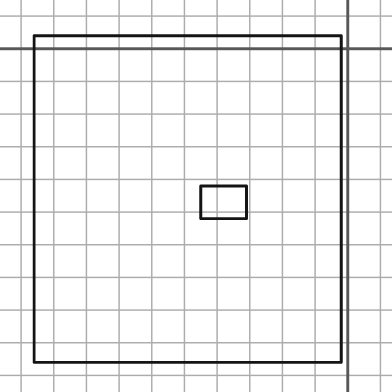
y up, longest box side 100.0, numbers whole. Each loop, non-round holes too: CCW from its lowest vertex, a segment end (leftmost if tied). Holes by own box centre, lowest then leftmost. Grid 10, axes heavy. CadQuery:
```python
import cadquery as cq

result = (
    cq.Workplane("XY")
    .moveTo(-96.0, -96.0)
    .lineTo(-2.0, -96.0)
    .lineTo(-2.0, 4.0)
    .lineTo(-96.0, 4.0)
    .close()
    .moveTo(-45.0, -52.0)
    .lineTo(-31.0, -52.0)
    .lineTo(-31.0, -42.0)
    .lineTo(-45.0, -42.0)
    .close()
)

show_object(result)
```